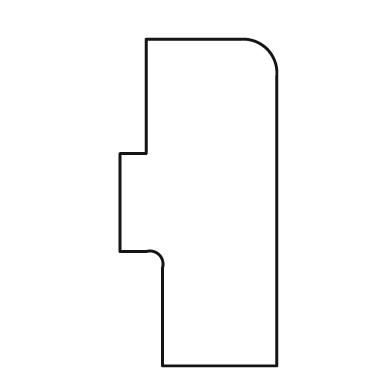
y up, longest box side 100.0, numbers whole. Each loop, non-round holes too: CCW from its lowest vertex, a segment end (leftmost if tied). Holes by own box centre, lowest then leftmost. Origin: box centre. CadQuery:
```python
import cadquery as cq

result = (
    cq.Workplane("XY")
    .moveTo(-11.0, -50.0)
    .lineTo(24.0, -50.0)
    .lineTo(24.0, 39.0)
    .threePointArc((21.0, 47.0), (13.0, 50.0))
    .lineTo(-16.0, 50.0)
    .lineTo(-16.0, 15.0)
    .lineTo(-24.0, 15.0)
    .lineTo(-24.0, -15.0)
    .lineTo(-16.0, -15.0)
    .threePointArc((-12.0, -16.0), (-11.0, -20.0))
    .close()
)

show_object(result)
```